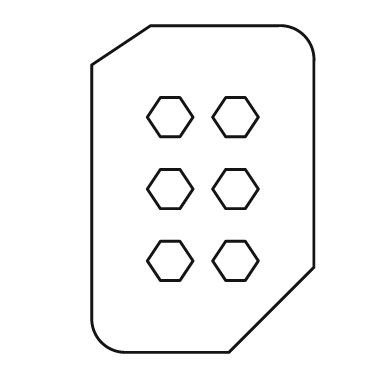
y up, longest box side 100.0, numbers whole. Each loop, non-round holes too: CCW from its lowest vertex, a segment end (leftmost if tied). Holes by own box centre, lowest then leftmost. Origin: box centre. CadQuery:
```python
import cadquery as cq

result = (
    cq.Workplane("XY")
    .moveTo(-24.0, -50.0)
    .lineTo(8.0, -50.0)
    .lineTo(34.0, -24.0)
    .lineTo(34.0, 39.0)
    .threePointArc((31.0, 47.0), (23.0, 50.0))
    .lineTo(-16.0, 50.0)
    .lineTo(-34.0, 38.0)
    .lineTo(-34.0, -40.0)
    .threePointArc((-31.0, -47.0), (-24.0, -50.0))
    .close()
    .moveTo(-13.0, -28.0)
    .lineTo(-7.0, -28.0)
    .lineTo(-3.0, -22.0)
    .lineTo(-7.0, -16.0)
    .lineTo(-13.0, -16.0)
    .lineTo(-17.0, -22.0)
    .close()
    .moveTo(7.0, -28.0)
    .lineTo(13.0, -28.0)
    .lineTo(17.0, -22.0)
    .lineTo(13.0, -16.0)
    .lineTo(7.0, -16.0)
    .lineTo(3.0, -22.0)
    .close()
    .moveTo(-13.0, -6.0)
    .lineTo(-7.0, -6.0)
    .lineTo(-3.0, 0.0)
    .lineTo(-7.0, 6.0)
    .lineTo(-13.0, 6.0)
    .lineTo(-17.0, 0.0)
    .close()
    .moveTo(7.0, -6.0)
    .lineTo(13.0, -6.0)
    .lineTo(17.0, 0.0)
    .lineTo(13.0, 6.0)
    .lineTo(7.0, 6.0)
    .lineTo(3.0, 0.0)
    .close()
    .moveTo(-13.0, 16.0)
    .lineTo(-7.0, 16.0)
    .lineTo(-3.0, 22.0)
    .lineTo(-7.0, 28.0)
    .lineTo(-13.0, 28.0)
    .lineTo(-17.0, 22.0)
    .close()
    .moveTo(7.0, 16.0)
    .lineTo(13.0, 16.0)
    .lineTo(17.0, 22.0)
    .lineTo(13.0, 28.0)
    .lineTo(7.0, 28.0)
    .lineTo(3.0, 22.0)
    .close()
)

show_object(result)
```